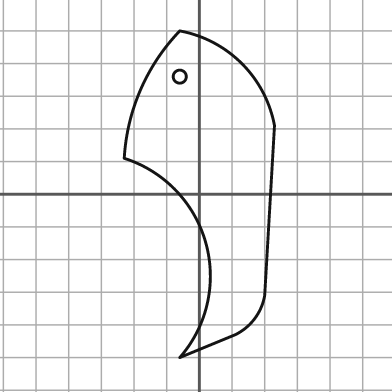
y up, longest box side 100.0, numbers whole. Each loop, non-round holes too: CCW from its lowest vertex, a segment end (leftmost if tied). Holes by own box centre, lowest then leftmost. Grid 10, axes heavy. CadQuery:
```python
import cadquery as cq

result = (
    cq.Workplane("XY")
    .moveTo(-6.0, -50.0)
    .lineTo(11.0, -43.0)
    .threePointArc((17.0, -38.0), (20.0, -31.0))
    .lineTo(23.0, 21.0)
    .threePointArc((13.0, 40.0), (-6.0, 50.0))
    .threePointArc((-18.0, 32.0), (-23.0, 11.0))
    .threePointArc((2.0, -15.0), (-6.0, -50.0))
    .close()
    .moveTo(-6.0, 36.0)
    .circle(2.0)
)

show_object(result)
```